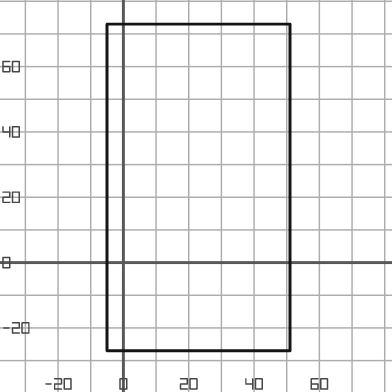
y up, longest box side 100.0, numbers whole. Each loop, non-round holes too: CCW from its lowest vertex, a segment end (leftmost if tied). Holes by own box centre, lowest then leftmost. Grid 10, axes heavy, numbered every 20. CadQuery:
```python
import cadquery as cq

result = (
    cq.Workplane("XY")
    .moveTo(-5.0, -27.0)
    .lineTo(51.0, -27.0)
    .lineTo(51.0, 73.0)
    .lineTo(-5.0, 73.0)
    .close()
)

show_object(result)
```